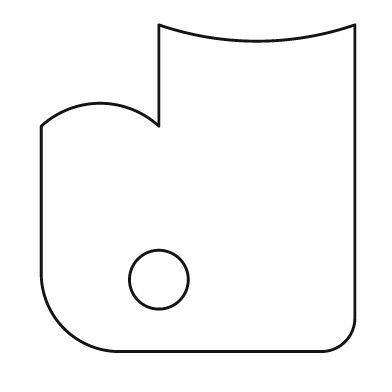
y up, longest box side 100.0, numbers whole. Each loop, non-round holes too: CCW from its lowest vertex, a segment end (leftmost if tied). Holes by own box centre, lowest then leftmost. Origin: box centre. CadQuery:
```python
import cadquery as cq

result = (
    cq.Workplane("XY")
    .moveTo(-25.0, -50.0)
    .lineTo(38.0, -50.0)
    .threePointArc((45.0, -47.0), (48.0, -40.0))
    .lineTo(48.0, 50.0)
    .threePointArc((18.0, 45.0), (-12.0, 50.0))
    .lineTo(-12.0, 19.0)
    .threePointArc((-30.0, 26.0), (-48.0, 19.0))
    .lineTo(-48.0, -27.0)
    .threePointArc((-41.0, -43.0), (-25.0, -50.0))
    .close()
    .moveTo(-12.0, -28.0)
    .circle(9.0)
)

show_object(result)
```